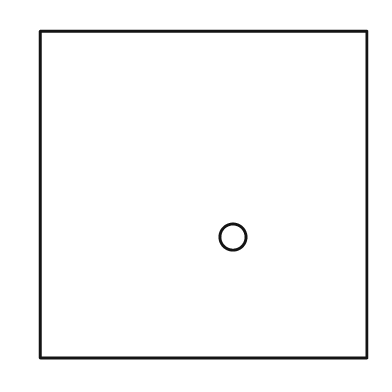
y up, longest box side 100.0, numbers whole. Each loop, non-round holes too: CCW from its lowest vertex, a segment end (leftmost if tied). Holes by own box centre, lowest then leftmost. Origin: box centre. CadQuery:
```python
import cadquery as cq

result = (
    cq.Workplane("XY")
    .moveTo(-50.0, -50.0)
    .lineTo(50.0, -50.0)
    .lineTo(50.0, 50.0)
    .lineTo(-50.0, 50.0)
    .close()
    .moveTo(9.0, -13.0)
    .circle(4.0)
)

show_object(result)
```